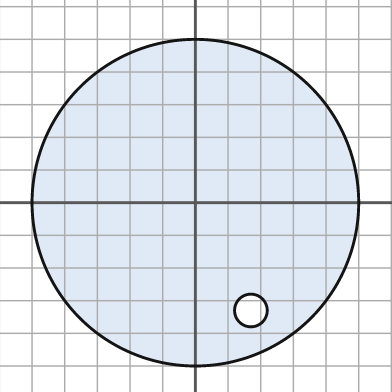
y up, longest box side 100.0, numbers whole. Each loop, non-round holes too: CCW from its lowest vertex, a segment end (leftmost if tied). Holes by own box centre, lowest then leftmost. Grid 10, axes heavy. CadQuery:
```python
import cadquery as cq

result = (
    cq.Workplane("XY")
    .moveTo(0.0, 0.0)
    .circle(50.0)
    .moveTo(17.0, -33.0)
    .circle(5.0)
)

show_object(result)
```